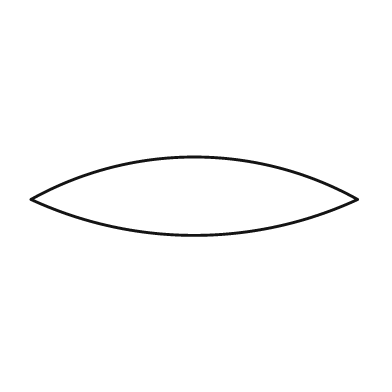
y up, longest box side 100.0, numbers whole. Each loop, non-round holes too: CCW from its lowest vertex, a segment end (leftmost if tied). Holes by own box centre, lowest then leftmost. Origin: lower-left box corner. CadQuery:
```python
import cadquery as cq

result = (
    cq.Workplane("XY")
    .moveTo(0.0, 11.0)
    .threePointArc((50.0, 0.0), (100.0, 11.0))
    .threePointArc((50.0, 24.0), (0.0, 11.0))
    .close()
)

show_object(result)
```